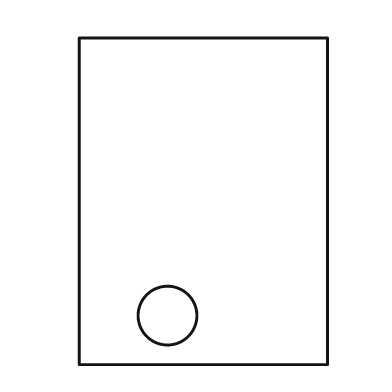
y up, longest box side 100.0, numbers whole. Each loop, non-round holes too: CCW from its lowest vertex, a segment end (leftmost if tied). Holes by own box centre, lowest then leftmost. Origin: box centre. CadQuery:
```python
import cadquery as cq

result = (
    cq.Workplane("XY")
    .moveTo(-38.0, -50.0)
    .lineTo(38.0, -50.0)
    .lineTo(38.0, 50.0)
    .lineTo(-38.0, 50.0)
    .close()
    .moveTo(-11.0, -35.0)
    .circle(9.0)
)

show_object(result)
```